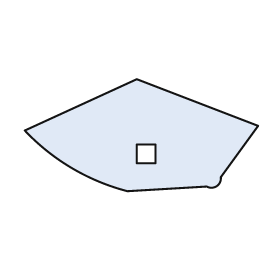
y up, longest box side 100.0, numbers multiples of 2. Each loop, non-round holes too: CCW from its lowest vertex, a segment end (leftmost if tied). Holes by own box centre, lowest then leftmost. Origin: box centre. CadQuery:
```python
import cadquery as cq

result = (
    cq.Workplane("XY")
    .moveTo(-6.0, -24.0)
    .lineTo(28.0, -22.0)
    .threePointArc((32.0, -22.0), (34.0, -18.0))
    .lineTo(50.0, 4.0)
    .lineTo(-2.0, 24.0)
    .lineTo(-50.0, 2.0)
    .threePointArc((-30.0, -14.0), (-6.0, -24.0))
    .close()
    .moveTo(-2.0, -12.0)
    .lineTo(6.0, -12.0)
    .lineTo(6.0, -4.0)
    .lineTo(-2.0, -4.0)
    .close()
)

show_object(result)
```